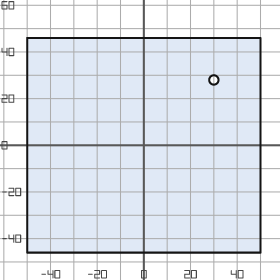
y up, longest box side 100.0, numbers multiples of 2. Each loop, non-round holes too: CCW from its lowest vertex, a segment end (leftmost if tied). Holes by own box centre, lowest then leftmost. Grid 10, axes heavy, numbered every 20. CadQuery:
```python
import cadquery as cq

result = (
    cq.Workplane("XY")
    .moveTo(-50.0, -46.0)
    .lineTo(50.0, -46.0)
    .lineTo(50.0, 46.0)
    .lineTo(-50.0, 46.0)
    .close()
    .moveTo(30.0, 28.0)
    .circle(2.0)
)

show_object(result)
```